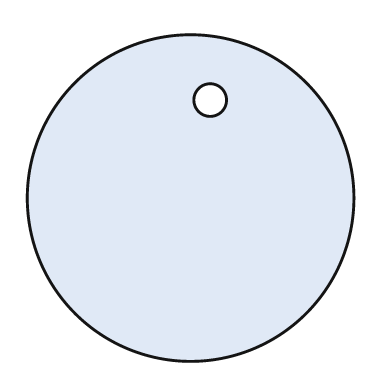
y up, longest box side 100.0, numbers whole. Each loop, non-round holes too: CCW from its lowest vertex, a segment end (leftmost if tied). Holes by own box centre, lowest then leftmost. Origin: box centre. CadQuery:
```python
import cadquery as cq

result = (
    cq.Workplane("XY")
    .moveTo(0.0, 0.0)
    .circle(50.0)
    .moveTo(6.0, 30.0)
    .circle(5.0)
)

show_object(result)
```